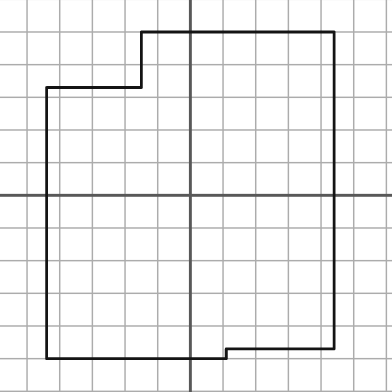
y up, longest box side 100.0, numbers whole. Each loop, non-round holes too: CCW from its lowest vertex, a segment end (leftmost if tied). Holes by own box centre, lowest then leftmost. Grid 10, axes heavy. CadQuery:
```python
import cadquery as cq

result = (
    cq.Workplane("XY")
    .moveTo(-44.0, -50.0)
    .lineTo(11.0, -50.0)
    .lineTo(11.0, -47.0)
    .lineTo(44.0, -47.0)
    .lineTo(44.0, 50.0)
    .lineTo(-15.0, 50.0)
    .lineTo(-15.0, 33.0)
    .lineTo(-44.0, 33.0)
    .close()
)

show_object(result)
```